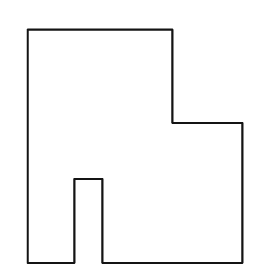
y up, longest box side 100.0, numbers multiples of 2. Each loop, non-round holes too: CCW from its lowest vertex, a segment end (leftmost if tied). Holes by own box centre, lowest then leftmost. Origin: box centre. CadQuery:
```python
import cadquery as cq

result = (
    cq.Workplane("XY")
    .moveTo(-46.0, -50.0)
    .lineTo(-26.0, -50.0)
    .lineTo(-26.0, -14.0)
    .lineTo(-14.0, -14.0)
    .lineTo(-14.0, -50.0)
    .lineTo(46.0, -50.0)
    .lineTo(46.0, 10.0)
    .lineTo(16.0, 10.0)
    .lineTo(16.0, 50.0)
    .lineTo(-46.0, 50.0)
    .close()
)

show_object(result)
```